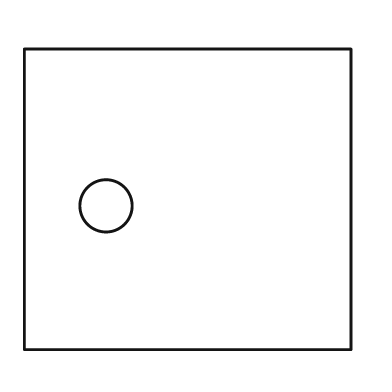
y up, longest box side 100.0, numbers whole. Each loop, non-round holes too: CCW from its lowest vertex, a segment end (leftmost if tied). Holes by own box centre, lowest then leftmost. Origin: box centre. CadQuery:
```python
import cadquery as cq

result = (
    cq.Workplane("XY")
    .moveTo(-50.0, -46.0)
    .lineTo(50.0, -46.0)
    .lineTo(50.0, 46.0)
    .lineTo(-50.0, 46.0)
    .close()
    .moveTo(-25.0, -2.0)
    .circle(8.0)
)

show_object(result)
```